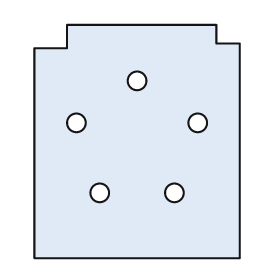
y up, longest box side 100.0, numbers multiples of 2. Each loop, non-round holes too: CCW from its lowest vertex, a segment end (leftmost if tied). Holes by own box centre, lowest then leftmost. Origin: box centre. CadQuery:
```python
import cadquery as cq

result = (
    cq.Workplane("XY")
    .moveTo(-44.0, -50.0)
    .lineTo(44.0, -50.0)
    .lineTo(44.0, 42.0)
    .lineTo(34.0, 42.0)
    .lineTo(34.0, 50.0)
    .lineTo(-30.0, 50.0)
    .lineTo(-30.0, 40.0)
    .lineTo(-44.0, 40.0)
    .close()
    .moveTo(-16.0, -22.0)
    .circle(4.0)
    .moveTo(16.0, -22.0)
    .circle(4.0)
    .moveTo(-26.0, 8.0)
    .circle(4.0)
    .moveTo(26.0, 8.0)
    .circle(4.0)
    .moveTo(0.0, 26.0)
    .circle(4.0)
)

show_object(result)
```